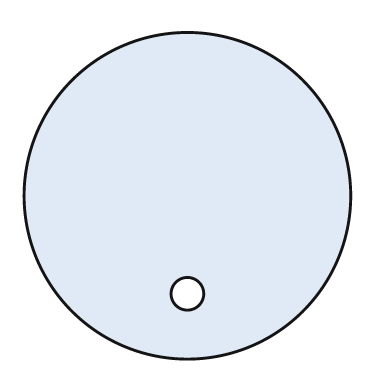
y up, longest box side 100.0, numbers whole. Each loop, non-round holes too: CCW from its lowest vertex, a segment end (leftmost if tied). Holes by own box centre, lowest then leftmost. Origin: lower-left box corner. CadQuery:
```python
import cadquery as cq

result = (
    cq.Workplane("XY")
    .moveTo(50.0, 50.0)
    .circle(50.0)
    .moveTo(50.0, 20.0)
    .circle(5.0)
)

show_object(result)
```